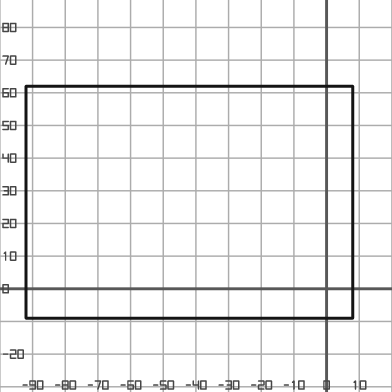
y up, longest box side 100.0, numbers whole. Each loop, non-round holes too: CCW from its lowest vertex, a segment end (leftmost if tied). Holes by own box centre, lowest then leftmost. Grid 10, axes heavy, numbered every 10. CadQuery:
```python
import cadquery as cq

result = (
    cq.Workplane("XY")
    .moveTo(-92.0, -9.0)
    .lineTo(8.0, -9.0)
    .lineTo(8.0, 62.0)
    .lineTo(-92.0, 62.0)
    .close()
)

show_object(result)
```